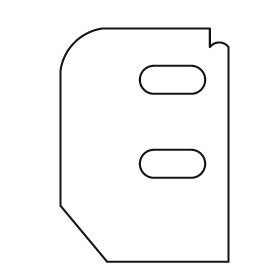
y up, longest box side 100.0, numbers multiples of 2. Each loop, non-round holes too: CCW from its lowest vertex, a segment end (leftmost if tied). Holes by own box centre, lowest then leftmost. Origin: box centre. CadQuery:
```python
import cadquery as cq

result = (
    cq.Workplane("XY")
    .moveTo(-16.0, -50.0)
    .lineTo(36.0, -50.0)
    .lineTo(36.0, 42.0)
    .threePointArc((32.0, 44.0), (28.0, 42.0))
    .lineTo(28.0, 50.0)
    .lineTo(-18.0, 50.0)
    .threePointArc((-30.0, 44.0), (-36.0, 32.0))
    .lineTo(-36.0, -26.0)
    .close()
    .moveTo(4.0, -14.0)
    .lineTo(20.0, -14.0)
    .threePointArc((26.0, -8.0), (20.0, -2.0))
    .lineTo(4.0, -2.0)
    .threePointArc((-2.0, -8.0), (4.0, -14.0))
    .close()
    .moveTo(4.0, 22.0)
    .lineTo(20.0, 22.0)
    .threePointArc((26.0, 28.0), (20.0, 34.0))
    .lineTo(4.0, 34.0)
    .threePointArc((-2.0, 28.0), (4.0, 22.0))
    .close()
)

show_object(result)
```